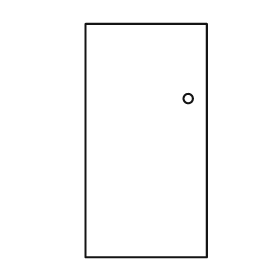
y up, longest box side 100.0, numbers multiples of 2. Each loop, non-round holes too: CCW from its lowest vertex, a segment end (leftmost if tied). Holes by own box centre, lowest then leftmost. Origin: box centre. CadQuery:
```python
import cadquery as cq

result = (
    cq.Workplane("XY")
    .moveTo(-26.0, -50.0)
    .lineTo(26.0, -50.0)
    .lineTo(26.0, 50.0)
    .lineTo(-26.0, 50.0)
    .close()
    .moveTo(18.0, 18.0)
    .circle(2.0)
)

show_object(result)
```